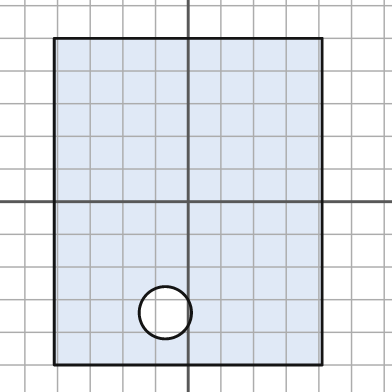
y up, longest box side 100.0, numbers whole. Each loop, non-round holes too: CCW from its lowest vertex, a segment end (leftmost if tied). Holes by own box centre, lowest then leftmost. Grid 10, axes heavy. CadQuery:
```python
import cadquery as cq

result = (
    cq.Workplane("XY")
    .moveTo(-41.0, -50.0)
    .lineTo(41.0, -50.0)
    .lineTo(41.0, 50.0)
    .lineTo(-41.0, 50.0)
    .close()
    .moveTo(-7.0, -34.0)
    .circle(8.0)
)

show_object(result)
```